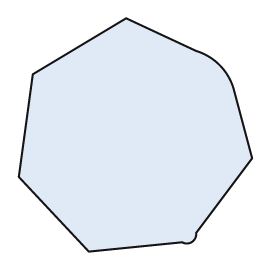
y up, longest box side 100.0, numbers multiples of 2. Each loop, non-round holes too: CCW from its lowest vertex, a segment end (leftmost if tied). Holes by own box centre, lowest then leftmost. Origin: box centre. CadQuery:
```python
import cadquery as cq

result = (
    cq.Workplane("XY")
    .moveTo(-20.0, -50.0)
    .lineTo(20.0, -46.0)
    .threePointArc((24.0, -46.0), (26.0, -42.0))
    .lineTo(50.0, -10.0)
    .lineTo(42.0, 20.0)
    .threePointArc((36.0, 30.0), (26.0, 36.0))
    .lineTo(-4.0, 50.0)
    .lineTo(-44.0, 26.0)
    .lineTo(-50.0, -18.0)
    .close()
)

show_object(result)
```